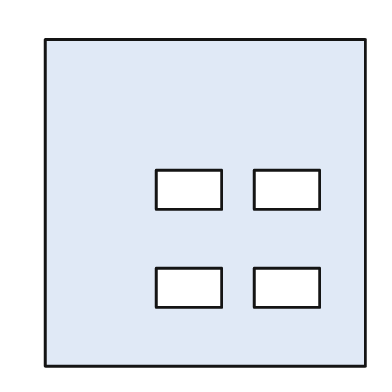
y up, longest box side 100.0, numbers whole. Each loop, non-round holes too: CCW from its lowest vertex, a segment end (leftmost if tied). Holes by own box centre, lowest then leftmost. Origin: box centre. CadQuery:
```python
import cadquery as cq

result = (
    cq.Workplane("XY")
    .moveTo(-49.0, -50.0)
    .lineTo(49.0, -50.0)
    .lineTo(49.0, 50.0)
    .lineTo(-49.0, 50.0)
    .close()
    .moveTo(-15.0, -32.0)
    .lineTo(5.0, -32.0)
    .lineTo(5.0, -20.0)
    .lineTo(-15.0, -20.0)
    .close()
    .moveTo(15.0, -32.0)
    .lineTo(35.0, -32.0)
    .lineTo(35.0, -20.0)
    .lineTo(15.0, -20.0)
    .close()
    .moveTo(-15.0, -2.0)
    .lineTo(5.0, -2.0)
    .lineTo(5.0, 10.0)
    .lineTo(-15.0, 10.0)
    .close()
    .moveTo(15.0, -2.0)
    .lineTo(35.0, -2.0)
    .lineTo(35.0, 10.0)
    .lineTo(15.0, 10.0)
    .close()
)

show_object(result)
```